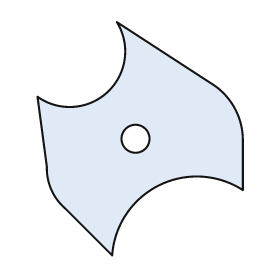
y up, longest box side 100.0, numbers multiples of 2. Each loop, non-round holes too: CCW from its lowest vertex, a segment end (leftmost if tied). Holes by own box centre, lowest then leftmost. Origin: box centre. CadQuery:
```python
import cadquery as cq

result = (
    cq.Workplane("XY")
    .moveTo(-12.0, -50.0)
    .threePointArc((8.0, -20.0), (44.0, -22.0))
    .lineTo(44.0, 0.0)
    .threePointArc((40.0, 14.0), (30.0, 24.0))
    .lineTo(-10.0, 50.0)
    .threePointArc((-14.0, 20.0), (-44.0, 18.0))
    .lineTo(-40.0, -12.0)
    .threePointArc((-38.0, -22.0), (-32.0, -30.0))
    .close()
    .moveTo(-2.0, 0.0)
    .circle(6.0)
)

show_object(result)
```